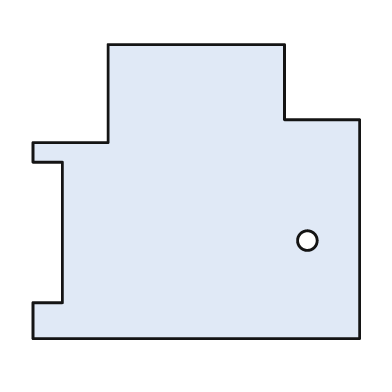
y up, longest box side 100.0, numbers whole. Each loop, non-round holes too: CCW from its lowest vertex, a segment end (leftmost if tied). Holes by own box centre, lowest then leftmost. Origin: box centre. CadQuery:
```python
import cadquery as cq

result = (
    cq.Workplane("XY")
    .moveTo(-50.0, -45.0)
    .lineTo(50.0, -45.0)
    .lineTo(50.0, 22.0)
    .lineTo(27.0, 22.0)
    .lineTo(27.0, 45.0)
    .lineTo(-27.0, 45.0)
    .lineTo(-27.0, 15.0)
    .lineTo(-50.0, 15.0)
    .lineTo(-50.0, 9.0)
    .lineTo(-41.0, 9.0)
    .lineTo(-41.0, -34.0)
    .lineTo(-50.0, -34.0)
    .close()
    .moveTo(34.0, -15.0)
    .circle(3.0)
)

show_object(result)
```